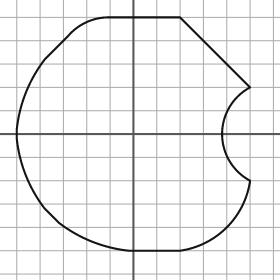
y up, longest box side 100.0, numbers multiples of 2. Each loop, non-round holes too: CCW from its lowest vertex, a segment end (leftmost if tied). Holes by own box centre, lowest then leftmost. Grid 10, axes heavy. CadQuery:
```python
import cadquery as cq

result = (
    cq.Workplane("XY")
    .moveTo(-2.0, -50.0)
    .lineTo(20.0, -50.0)
    .threePointArc((40.0, -40.0), (50.0, -20.0))
    .threePointArc((38.0, 0.0), (50.0, 20.0))
    .lineTo(20.0, 50.0)
    .lineTo(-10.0, 50.0)
    .threePointArc((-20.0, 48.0), (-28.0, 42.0))
    .lineTo(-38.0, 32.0)
    .threePointArc((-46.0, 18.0), (-50.0, 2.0))
    .lineTo(-50.0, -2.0)
    .threePointArc((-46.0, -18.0), (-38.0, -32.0))
    .lineTo(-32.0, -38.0)
    .threePointArc((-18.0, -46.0), (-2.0, -50.0))
    .close()
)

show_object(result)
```